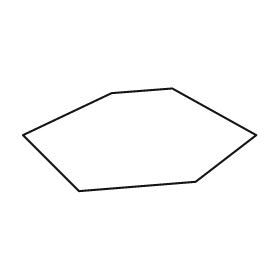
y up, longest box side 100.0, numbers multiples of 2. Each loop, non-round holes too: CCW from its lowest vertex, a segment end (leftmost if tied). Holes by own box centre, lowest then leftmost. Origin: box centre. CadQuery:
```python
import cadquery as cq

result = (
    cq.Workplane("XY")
    .moveTo(-26.0, -22.0)
    .lineTo(24.0, -18.0)
    .lineTo(50.0, 2.0)
    .lineTo(14.0, 22.0)
    .lineTo(-12.0, 20.0)
    .lineTo(-50.0, 2.0)
    .close()
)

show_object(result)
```